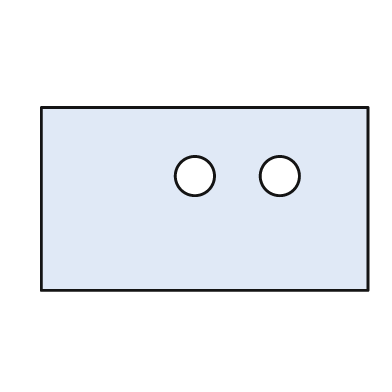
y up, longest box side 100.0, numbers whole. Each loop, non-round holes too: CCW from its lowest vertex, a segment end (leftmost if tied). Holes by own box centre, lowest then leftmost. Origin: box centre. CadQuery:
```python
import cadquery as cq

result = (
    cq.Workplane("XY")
    .moveTo(-50.0, -28.0)
    .lineTo(50.0, -28.0)
    .lineTo(50.0, 28.0)
    .lineTo(-50.0, 28.0)
    .close()
    .moveTo(-3.0, 7.0)
    .circle(6.0)
    .moveTo(23.0, 7.0)
    .circle(6.0)
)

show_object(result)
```